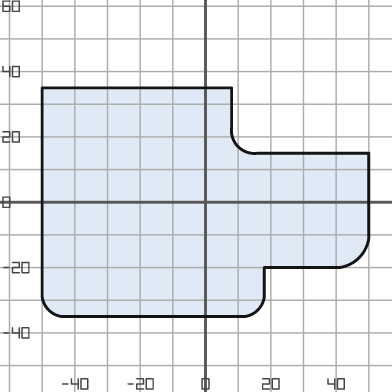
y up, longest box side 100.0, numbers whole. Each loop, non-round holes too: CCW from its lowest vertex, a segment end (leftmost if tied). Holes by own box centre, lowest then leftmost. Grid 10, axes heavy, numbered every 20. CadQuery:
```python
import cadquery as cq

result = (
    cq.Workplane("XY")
    .moveTo(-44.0, -35.0)
    .lineTo(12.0, -35.0)
    .threePointArc((16.0, -33.0), (18.0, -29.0))
    .lineTo(18.0, -20.0)
    .lineTo(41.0, -20.0)
    .threePointArc((47.0, -17.0), (50.0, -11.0))
    .lineTo(50.0, 15.0)
    .lineTo(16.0, 15.0)
    .threePointArc((10.0, 17.0), (8.0, 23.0))
    .lineTo(8.0, 35.0)
    .lineTo(-50.0, 35.0)
    .lineTo(-50.0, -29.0)
    .threePointArc((-48.0, -33.0), (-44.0, -35.0))
    .close()
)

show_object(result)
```